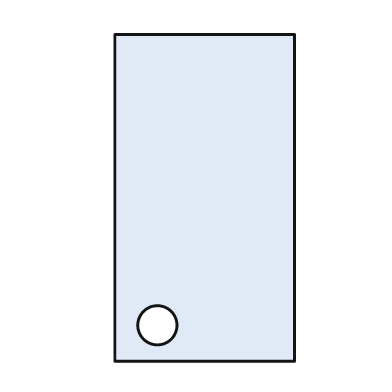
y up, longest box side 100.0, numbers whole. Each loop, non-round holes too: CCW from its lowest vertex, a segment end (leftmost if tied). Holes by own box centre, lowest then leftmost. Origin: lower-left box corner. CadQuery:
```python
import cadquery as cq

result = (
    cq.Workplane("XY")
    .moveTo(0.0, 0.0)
    .lineTo(55.0, 0.0)
    .lineTo(55.0, 100.0)
    .lineTo(0.0, 100.0)
    .close()
    .moveTo(13.0, 11.0)
    .circle(6.0)
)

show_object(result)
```